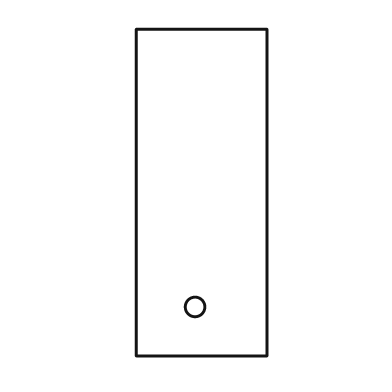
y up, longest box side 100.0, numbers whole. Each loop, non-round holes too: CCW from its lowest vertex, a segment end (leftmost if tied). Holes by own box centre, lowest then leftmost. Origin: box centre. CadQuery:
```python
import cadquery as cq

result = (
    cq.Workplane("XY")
    .moveTo(-20.0, -50.0)
    .lineTo(20.0, -50.0)
    .lineTo(20.0, 50.0)
    .lineTo(-20.0, 50.0)
    .close()
    .moveTo(-2.0, -35.0)
    .circle(3.0)
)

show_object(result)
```